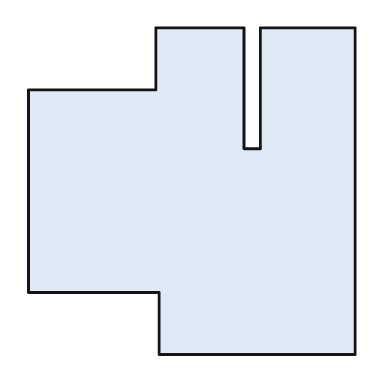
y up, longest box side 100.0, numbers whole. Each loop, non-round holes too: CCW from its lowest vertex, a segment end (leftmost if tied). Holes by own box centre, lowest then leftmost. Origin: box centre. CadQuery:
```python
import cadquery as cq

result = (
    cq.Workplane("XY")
    .moveTo(-10.0, -50.0)
    .lineTo(50.0, -50.0)
    .lineTo(50.0, 50.0)
    .lineTo(21.0, 50.0)
    .lineTo(21.0, 13.0)
    .lineTo(16.0, 13.0)
    .lineTo(16.0, 50.0)
    .lineTo(-11.0, 50.0)
    .lineTo(-11.0, 31.0)
    .lineTo(-50.0, 31.0)
    .lineTo(-50.0, -31.0)
    .lineTo(-10.0, -31.0)
    .close()
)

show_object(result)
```